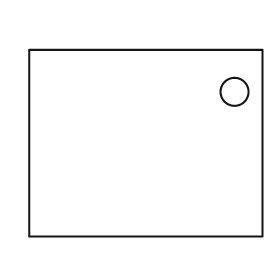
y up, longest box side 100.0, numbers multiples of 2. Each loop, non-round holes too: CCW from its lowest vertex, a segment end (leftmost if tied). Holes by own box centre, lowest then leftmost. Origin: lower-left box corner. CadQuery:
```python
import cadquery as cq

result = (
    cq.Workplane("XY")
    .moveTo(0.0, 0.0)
    .lineTo(100.0, 0.0)
    .lineTo(100.0, 80.0)
    .lineTo(0.0, 80.0)
    .close()
    .moveTo(88.0, 62.0)
    .circle(6.0)
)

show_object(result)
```